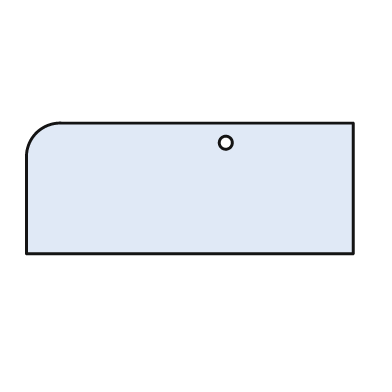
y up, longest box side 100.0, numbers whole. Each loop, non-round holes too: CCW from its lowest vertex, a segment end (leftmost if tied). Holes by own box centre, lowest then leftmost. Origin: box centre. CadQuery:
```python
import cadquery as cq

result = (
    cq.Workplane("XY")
    .moveTo(-50.0, -20.0)
    .lineTo(50.0, -20.0)
    .lineTo(50.0, 20.0)
    .lineTo(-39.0, 20.0)
    .threePointArc((-47.0, 17.0), (-50.0, 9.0))
    .close()
    .moveTo(11.0, 14.0)
    .circle(2.0)
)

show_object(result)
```